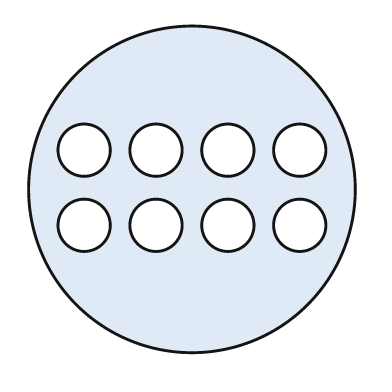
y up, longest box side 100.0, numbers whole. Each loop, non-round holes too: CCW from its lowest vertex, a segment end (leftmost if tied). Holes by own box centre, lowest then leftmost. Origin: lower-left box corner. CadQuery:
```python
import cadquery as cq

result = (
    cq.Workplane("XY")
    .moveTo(50.0, 50.0)
    .circle(50.0)
    .moveTo(17.0, 39.0)
    .circle(8.0)
    .moveTo(39.0, 39.0)
    .circle(8.0)
    .moveTo(61.0, 39.0)
    .circle(8.0)
    .moveTo(83.0, 39.0)
    .circle(8.0)
    .moveTo(17.0, 62.0)
    .circle(8.0)
    .moveTo(39.0, 62.0)
    .circle(8.0)
    .moveTo(61.0, 62.0)
    .circle(8.0)
    .moveTo(83.0, 62.0)
    .circle(8.0)
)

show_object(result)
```